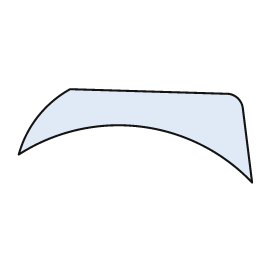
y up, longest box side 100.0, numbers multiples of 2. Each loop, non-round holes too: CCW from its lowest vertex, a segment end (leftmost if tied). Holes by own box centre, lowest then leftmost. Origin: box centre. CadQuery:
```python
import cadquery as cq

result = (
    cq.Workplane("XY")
    .moveTo(50.0, -20.0)
    .lineTo(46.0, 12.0)
    .threePointArc((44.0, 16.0), (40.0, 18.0))
    .lineTo(-28.0, 20.0)
    .threePointArc((-42.0, 8.0), (-50.0, -8.0))
    .threePointArc((2.0, 4.0), (50.0, -20.0))
    .close()
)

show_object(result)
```